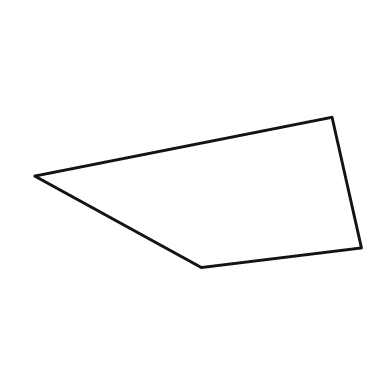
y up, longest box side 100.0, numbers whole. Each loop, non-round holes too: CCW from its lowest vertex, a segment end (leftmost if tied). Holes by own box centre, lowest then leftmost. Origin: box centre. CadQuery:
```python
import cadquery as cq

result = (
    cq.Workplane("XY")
    .moveTo(1.0, -23.0)
    .lineTo(50.0, -17.0)
    .lineTo(41.0, 23.0)
    .lineTo(-50.0, 5.0)
    .close()
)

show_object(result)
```